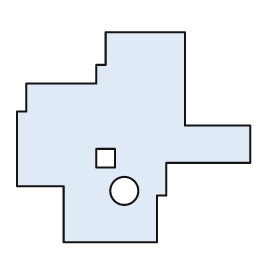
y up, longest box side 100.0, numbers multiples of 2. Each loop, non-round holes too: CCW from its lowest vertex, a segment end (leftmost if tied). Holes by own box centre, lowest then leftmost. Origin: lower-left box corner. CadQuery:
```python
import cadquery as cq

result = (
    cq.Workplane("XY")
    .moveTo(20.0, 0.0)
    .lineTo(60.0, 0.0)
    .lineTo(60.0, 20.0)
    .lineTo(64.0, 20.0)
    .lineTo(64.0, 34.0)
    .lineTo(100.0, 34.0)
    .lineTo(100.0, 50.0)
    .lineTo(72.0, 50.0)
    .lineTo(72.0, 90.0)
    .lineTo(38.0, 90.0)
    .lineTo(38.0, 76.0)
    .lineTo(34.0, 76.0)
    .lineTo(34.0, 68.0)
    .lineTo(4.0, 68.0)
    .lineTo(4.0, 56.0)
    .lineTo(0.0, 56.0)
    .lineTo(0.0, 24.0)
    .lineTo(20.0, 24.0)
    .close()
    .moveTo(46.0, 22.0)
    .circle(6.0)
    .moveTo(34.0, 32.0)
    .lineTo(42.0, 32.0)
    .lineTo(42.0, 40.0)
    .lineTo(34.0, 40.0)
    .close()
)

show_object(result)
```